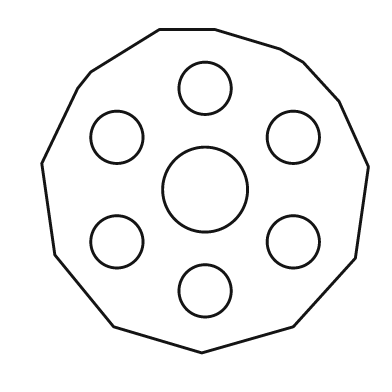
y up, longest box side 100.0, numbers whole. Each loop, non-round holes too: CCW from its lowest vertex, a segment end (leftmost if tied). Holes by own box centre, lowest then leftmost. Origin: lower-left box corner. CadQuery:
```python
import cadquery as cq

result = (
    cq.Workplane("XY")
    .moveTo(49.0, 0.0)
    .lineTo(77.0, 8.0)
    .lineTo(96.0, 29.0)
    .lineTo(100.0, 57.0)
    .lineTo(91.0, 77.0)
    .lineTo(80.0, 89.0)
    .lineTo(73.0, 93.0)
    .lineTo(53.0, 99.0)
    .lineTo(36.0, 99.0)
    .lineTo(15.0, 86.0)
    .lineTo(11.0, 81.0)
    .lineTo(0.0, 58.0)
    .lineTo(4.0, 30.0)
    .lineTo(22.0, 8.0)
    .close()
    .moveTo(50.0, 19.0)
    .circle(8.0)
    .moveTo(23.0, 34.0)
    .circle(8.0)
    .moveTo(77.0, 34.0)
    .circle(8.0)
    .moveTo(50.0, 50.0)
    .circle(13.0)
    .moveTo(23.0, 66.0)
    .circle(8.0)
    .moveTo(77.0, 66.0)
    .circle(8.0)
    .moveTo(50.0, 81.0)
    .circle(8.0)
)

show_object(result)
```